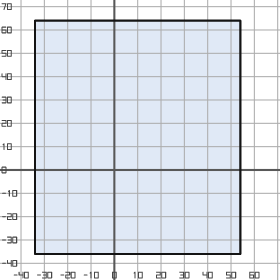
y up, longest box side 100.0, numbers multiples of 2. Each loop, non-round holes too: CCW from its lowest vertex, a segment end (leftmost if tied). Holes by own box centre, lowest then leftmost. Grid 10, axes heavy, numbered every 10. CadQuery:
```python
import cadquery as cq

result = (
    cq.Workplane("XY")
    .moveTo(-34.0, -36.0)
    .lineTo(54.0, -36.0)
    .lineTo(54.0, 64.0)
    .lineTo(-34.0, 64.0)
    .close()
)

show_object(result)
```